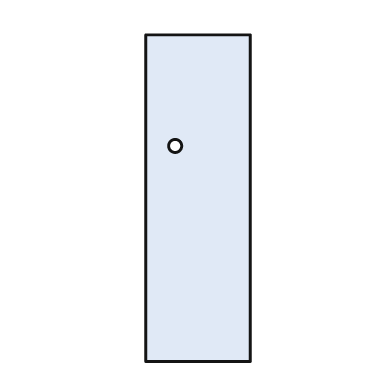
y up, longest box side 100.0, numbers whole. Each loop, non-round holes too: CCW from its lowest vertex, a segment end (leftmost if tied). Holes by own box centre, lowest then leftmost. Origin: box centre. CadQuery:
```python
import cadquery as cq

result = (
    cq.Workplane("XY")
    .moveTo(-16.0, -50.0)
    .lineTo(16.0, -50.0)
    .lineTo(16.0, 50.0)
    .lineTo(-16.0, 50.0)
    .close()
    .moveTo(-7.0, 16.0)
    .circle(2.0)
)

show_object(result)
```